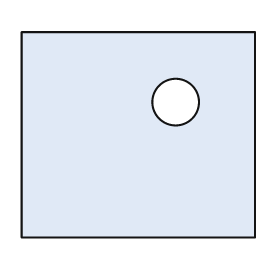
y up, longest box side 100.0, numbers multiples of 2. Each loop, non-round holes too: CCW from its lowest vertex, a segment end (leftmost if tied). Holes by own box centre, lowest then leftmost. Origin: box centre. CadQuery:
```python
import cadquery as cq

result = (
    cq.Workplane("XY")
    .moveTo(-50.0, -44.0)
    .lineTo(50.0, -44.0)
    .lineTo(50.0, 44.0)
    .lineTo(-50.0, 44.0)
    .close()
    .moveTo(16.0, 14.0)
    .circle(10.0)
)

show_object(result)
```